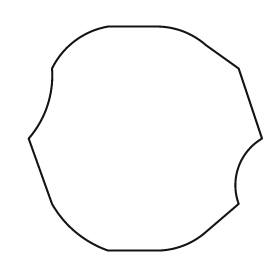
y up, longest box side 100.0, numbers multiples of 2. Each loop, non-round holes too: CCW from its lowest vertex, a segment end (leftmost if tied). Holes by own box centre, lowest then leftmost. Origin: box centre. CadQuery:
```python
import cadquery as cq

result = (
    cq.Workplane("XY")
    .moveTo(-16.0, -48.0)
    .lineTo(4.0, -48.0)
    .threePointArc((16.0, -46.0), (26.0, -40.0))
    .lineTo(40.0, -28.0)
    .threePointArc((40.0, -12.0), (50.0, 0.0))
    .lineTo(40.0, 30.0)
    .lineTo(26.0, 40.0)
    .threePointArc((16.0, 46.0), (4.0, 48.0))
    .lineTo(-16.0, 48.0)
    .threePointArc((-30.0, 42.0), (-40.0, 30.0))
    .threePointArc((-42.0, 14.0), (-50.0, 0.0))
    .lineTo(-40.0, -28.0)
    .threePointArc((-30.0, -40.0), (-16.0, -48.0))
    .close()
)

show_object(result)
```